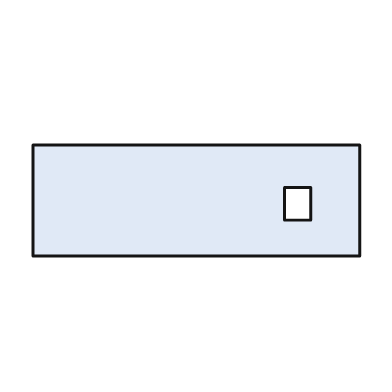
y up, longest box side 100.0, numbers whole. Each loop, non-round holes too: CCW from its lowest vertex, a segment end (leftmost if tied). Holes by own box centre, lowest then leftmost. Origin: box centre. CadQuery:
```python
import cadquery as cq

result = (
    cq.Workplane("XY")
    .moveTo(-50.0, -17.0)
    .lineTo(50.0, -17.0)
    .lineTo(50.0, 17.0)
    .lineTo(-50.0, 17.0)
    .close()
    .moveTo(27.0, -6.0)
    .lineTo(35.0, -6.0)
    .lineTo(35.0, 4.0)
    .lineTo(27.0, 4.0)
    .close()
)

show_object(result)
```